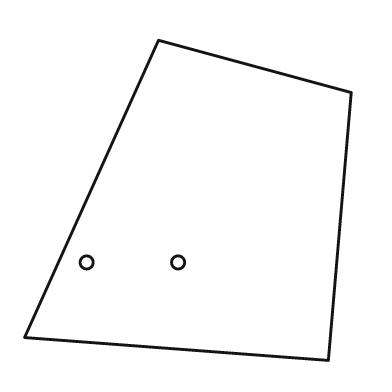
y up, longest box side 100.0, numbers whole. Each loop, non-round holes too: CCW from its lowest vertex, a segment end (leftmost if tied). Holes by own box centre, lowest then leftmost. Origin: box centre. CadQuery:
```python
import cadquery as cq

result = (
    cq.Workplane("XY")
    .moveTo(43.0, -49.0)
    .lineTo(50.0, 33.0)
    .lineTo(-9.0, 49.0)
    .lineTo(-50.0, -42.0)
    .close()
    .moveTo(-31.0, -19.0)
    .circle(2.0)
    .moveTo(-3.0, -19.0)
    .circle(2.0)
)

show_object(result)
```